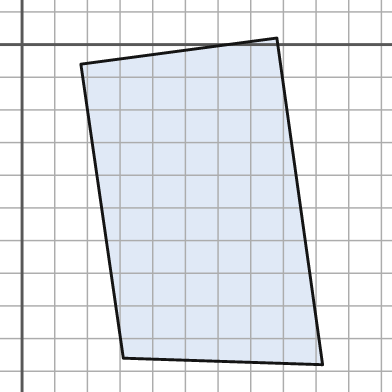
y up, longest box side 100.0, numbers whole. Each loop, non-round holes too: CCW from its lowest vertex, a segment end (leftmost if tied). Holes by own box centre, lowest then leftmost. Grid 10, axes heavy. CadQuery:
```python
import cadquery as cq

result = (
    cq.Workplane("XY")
    .moveTo(92.0, -98.0)
    .lineTo(78.0, 2.0)
    .lineTo(18.0, -6.0)
    .lineTo(31.0, -96.0)
    .close()
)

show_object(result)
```